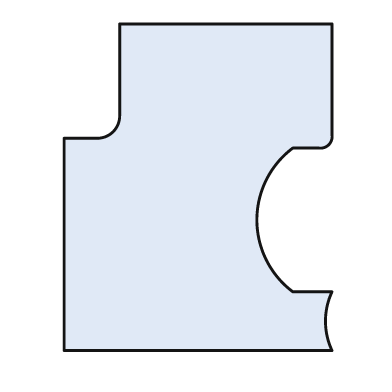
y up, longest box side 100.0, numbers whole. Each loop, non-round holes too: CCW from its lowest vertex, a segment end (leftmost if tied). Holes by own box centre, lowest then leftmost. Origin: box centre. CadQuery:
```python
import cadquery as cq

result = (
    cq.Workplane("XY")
    .moveTo(-41.0, -50.0)
    .lineTo(41.0, -50.0)
    .threePointArc((39.0, -41.0), (41.0, -32.0))
    .lineTo(29.0, -32.0)
    .threePointArc((18.0, -10.0), (29.0, 12.0))
    .lineTo(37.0, 12.0)
    .threePointArc((40.0, 13.0), (41.0, 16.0))
    .lineTo(41.0, 50.0)
    .lineTo(-24.0, 50.0)
    .lineTo(-24.0, 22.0)
    .threePointArc((-26.0, 17.0), (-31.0, 15.0))
    .lineTo(-41.0, 15.0)
    .close()
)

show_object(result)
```